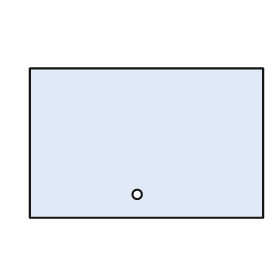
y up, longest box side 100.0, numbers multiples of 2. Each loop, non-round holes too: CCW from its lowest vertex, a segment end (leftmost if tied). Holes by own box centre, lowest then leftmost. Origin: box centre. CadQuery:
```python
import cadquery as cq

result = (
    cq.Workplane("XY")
    .moveTo(-50.0, -32.0)
    .lineTo(50.0, -32.0)
    .lineTo(50.0, 32.0)
    .lineTo(-50.0, 32.0)
    .close()
    .moveTo(-4.0, -22.0)
    .circle(2.0)
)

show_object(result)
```